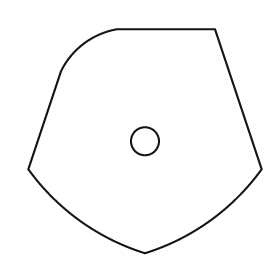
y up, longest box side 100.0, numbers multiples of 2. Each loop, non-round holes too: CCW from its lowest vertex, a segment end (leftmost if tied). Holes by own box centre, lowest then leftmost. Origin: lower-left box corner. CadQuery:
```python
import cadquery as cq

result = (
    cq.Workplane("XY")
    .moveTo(50.0, 0.0)
    .threePointArc((78.0, 14.0), (100.0, 36.0))
    .lineTo(80.0, 96.0)
    .lineTo(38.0, 96.0)
    .threePointArc((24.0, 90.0), (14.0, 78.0))
    .lineTo(0.0, 36.0)
    .threePointArc((22.0, 14.0), (50.0, 0.0))
    .close()
    .moveTo(50.0, 48.0)
    .circle(6.0)
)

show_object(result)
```